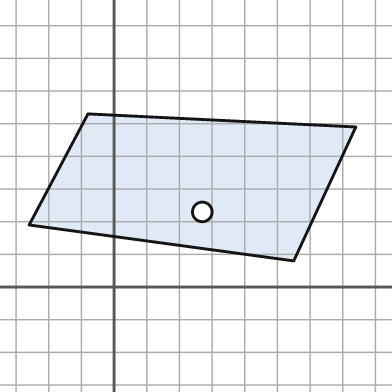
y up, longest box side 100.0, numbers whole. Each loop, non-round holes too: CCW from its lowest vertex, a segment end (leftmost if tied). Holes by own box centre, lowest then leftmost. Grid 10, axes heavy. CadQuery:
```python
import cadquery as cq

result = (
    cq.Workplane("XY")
    .moveTo(55.0, 8.0)
    .lineTo(74.0, 49.0)
    .lineTo(-8.0, 53.0)
    .lineTo(-26.0, 19.0)
    .close()
    .moveTo(27.0, 23.0)
    .circle(3.0)
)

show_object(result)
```